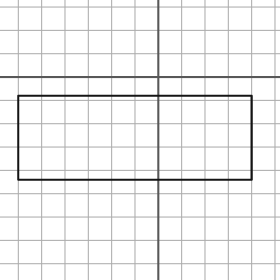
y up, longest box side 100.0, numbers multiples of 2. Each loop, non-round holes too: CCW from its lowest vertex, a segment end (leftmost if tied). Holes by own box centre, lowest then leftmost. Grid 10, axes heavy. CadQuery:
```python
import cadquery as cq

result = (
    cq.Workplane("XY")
    .moveTo(-60.0, -44.0)
    .lineTo(40.0, -44.0)
    .lineTo(40.0, -8.0)
    .lineTo(-60.0, -8.0)
    .close()
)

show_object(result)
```